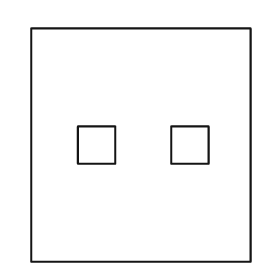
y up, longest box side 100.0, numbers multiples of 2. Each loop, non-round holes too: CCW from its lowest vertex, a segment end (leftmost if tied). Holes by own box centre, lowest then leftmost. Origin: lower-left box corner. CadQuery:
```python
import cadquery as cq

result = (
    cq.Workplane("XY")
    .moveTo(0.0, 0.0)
    .lineTo(94.0, 0.0)
    .lineTo(94.0, 100.0)
    .lineTo(0.0, 100.0)
    .close()
    .moveTo(20.0, 42.0)
    .lineTo(36.0, 42.0)
    .lineTo(36.0, 58.0)
    .lineTo(20.0, 58.0)
    .close()
    .moveTo(60.0, 42.0)
    .lineTo(76.0, 42.0)
    .lineTo(76.0, 58.0)
    .lineTo(60.0, 58.0)
    .close()
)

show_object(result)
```